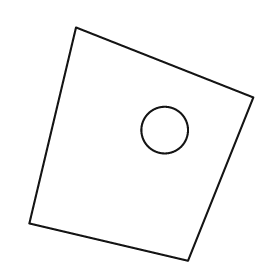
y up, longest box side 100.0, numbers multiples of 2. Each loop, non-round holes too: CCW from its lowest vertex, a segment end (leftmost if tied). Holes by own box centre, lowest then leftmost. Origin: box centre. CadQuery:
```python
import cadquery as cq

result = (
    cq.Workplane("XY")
    .moveTo(20.0, -50.0)
    .lineTo(48.0, 20.0)
    .lineTo(-28.0, 50.0)
    .lineTo(-48.0, -34.0)
    .close()
    .moveTo(10.0, 6.0)
    .circle(10.0)
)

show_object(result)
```